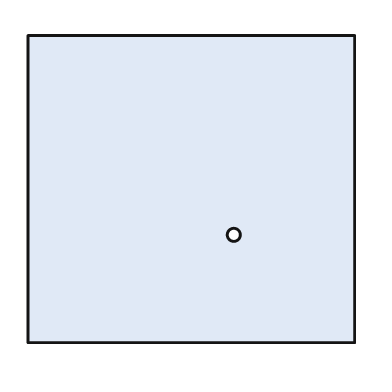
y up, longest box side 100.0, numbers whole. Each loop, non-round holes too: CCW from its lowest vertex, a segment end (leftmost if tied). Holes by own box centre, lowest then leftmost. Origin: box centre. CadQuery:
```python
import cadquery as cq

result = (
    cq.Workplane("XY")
    .moveTo(-50.0, -47.0)
    .lineTo(50.0, -47.0)
    .lineTo(50.0, 47.0)
    .lineTo(-50.0, 47.0)
    .close()
    .moveTo(13.0, -14.0)
    .circle(2.0)
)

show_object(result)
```